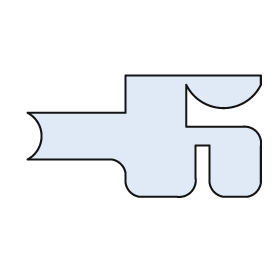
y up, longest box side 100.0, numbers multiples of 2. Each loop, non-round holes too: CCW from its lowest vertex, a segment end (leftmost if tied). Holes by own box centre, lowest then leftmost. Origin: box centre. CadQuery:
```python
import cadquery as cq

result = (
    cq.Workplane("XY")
    .moveTo(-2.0, -26.0)
    .lineTo(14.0, -26.0)
    .threePointArc((20.0, -24.0), (22.0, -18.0))
    .lineTo(22.0, -4.0)
    .lineTo(28.0, -4.0)
    .lineTo(28.0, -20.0)
    .threePointArc((30.0, -24.0), (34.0, -26.0))
    .lineTo(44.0, -26.0)
    .threePointArc((48.0, -24.0), (50.0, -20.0))
    .lineTo(50.0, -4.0)
    .threePointArc((48.0, 2.0), (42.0, 4.0))
    .lineTo(18.0, 4.0)
    .lineTo(18.0, 22.0)
    .threePointArc((34.0, 12.0), (50.0, 22.0))
    .lineTo(50.0, 26.0)
    .lineTo(-8.0, 26.0)
    .lineTo(-8.0, 10.0)
    .lineTo(-50.0, 10.0)
    .threePointArc((-44.0, 0.0), (-50.0, -10.0))
    .lineTo(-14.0, -10.0)
    .threePointArc((-10.0, -12.0), (-8.0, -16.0))
    .lineTo(-8.0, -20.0)
    .threePointArc((-6.0, -24.0), (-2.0, -26.0))
    .close()
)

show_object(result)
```